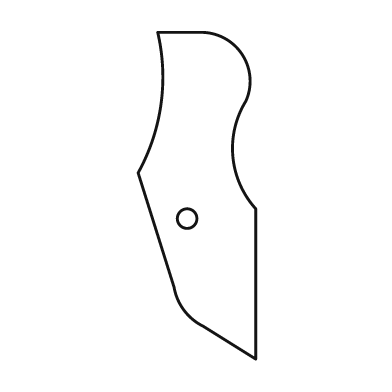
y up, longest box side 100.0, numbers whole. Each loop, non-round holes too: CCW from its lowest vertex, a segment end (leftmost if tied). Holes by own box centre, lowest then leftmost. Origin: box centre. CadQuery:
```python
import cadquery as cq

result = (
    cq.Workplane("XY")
    .moveTo(18.0, -50.0)
    .lineTo(18.0, -4.0)
    .threePointArc((11.0, 12.0), (15.0, 29.0))
    .threePointArc((14.0, 43.0), (2.0, 50.0))
    .lineTo(-12.0, 50.0)
    .threePointArc((-11.0, 28.0), (-18.0, 7.0))
    .lineTo(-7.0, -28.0)
    .threePointArc((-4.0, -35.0), (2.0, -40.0))
    .close()
    .moveTo(-3.0, -7.0)
    .circle(3.0)
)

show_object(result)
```